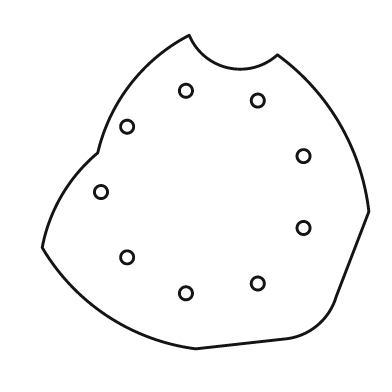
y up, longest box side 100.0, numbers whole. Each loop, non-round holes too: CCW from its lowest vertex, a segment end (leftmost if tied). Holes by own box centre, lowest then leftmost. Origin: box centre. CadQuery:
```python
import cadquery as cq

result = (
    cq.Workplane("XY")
    .moveTo(-3.0, -48.0)
    .lineTo(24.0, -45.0)
    .threePointArc((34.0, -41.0), (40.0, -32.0))
    .lineTo(50.0, -6.0)
    .threePointArc((41.0, 21.0), (22.0, 42.0))
    .threePointArc((7.0, 38.0), (-5.0, 48.0))
    .threePointArc((-23.0, 33.0), (-33.0, 12.0))
    .threePointArc((-44.0, -1.0), (-50.0, -17.0))
    .threePointArc((-30.0, -38.0), (-3.0, -48.0))
    .close()
    .moveTo(-6.0, -31.0)
    .circle(2.0)
    .moveTo(16.0, -28.0)
    .circle(2.0)
    .moveTo(-24.0, -20.0)
    .circle(2.0)
    .moveTo(30.0, -11.0)
    .circle(2.0)
    .moveTo(-32.0, 0.0)
    .circle(2.0)
    .moveTo(30.0, 11.0)
    .circle(2.0)
    .moveTo(-24.0, 20.0)
    .circle(2.0)
    .moveTo(16.0, 28.0)
    .circle(2.0)
    .moveTo(-6.0, 31.0)
    .circle(2.0)
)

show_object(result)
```